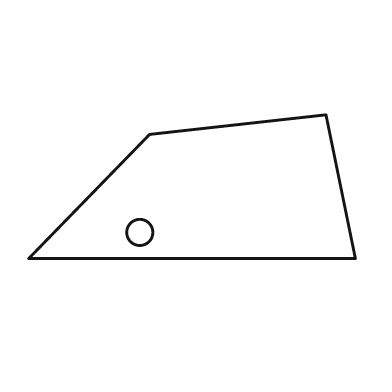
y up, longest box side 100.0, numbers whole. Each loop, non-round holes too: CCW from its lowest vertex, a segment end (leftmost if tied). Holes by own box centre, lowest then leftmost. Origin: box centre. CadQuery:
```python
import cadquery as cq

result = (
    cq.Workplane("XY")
    .moveTo(-50.0, -22.0)
    .lineTo(50.0, -22.0)
    .lineTo(41.0, 22.0)
    .lineTo(-13.0, 16.0)
    .close()
    .moveTo(-16.0, -14.0)
    .circle(4.0)
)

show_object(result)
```